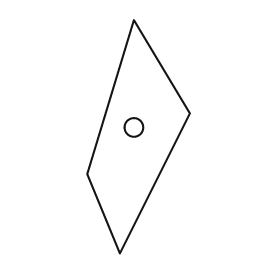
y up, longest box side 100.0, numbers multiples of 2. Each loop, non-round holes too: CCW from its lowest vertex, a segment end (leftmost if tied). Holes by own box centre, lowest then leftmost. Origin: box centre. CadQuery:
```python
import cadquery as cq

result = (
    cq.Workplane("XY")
    .moveTo(-8.0, -50.0)
    .lineTo(22.0, 10.0)
    .lineTo(-2.0, 50.0)
    .lineTo(-22.0, -16.0)
    .close()
    .moveTo(-2.0, 4.0)
    .circle(4.0)
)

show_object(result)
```